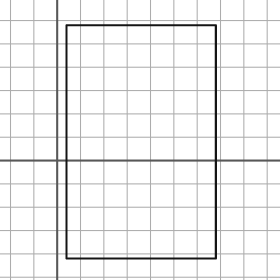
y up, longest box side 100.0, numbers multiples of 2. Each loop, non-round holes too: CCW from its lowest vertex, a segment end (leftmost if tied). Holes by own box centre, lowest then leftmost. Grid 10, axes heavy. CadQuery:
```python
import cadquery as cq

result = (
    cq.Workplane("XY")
    .moveTo(4.0, -42.0)
    .lineTo(68.0, -42.0)
    .lineTo(68.0, 58.0)
    .lineTo(4.0, 58.0)
    .close()
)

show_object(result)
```